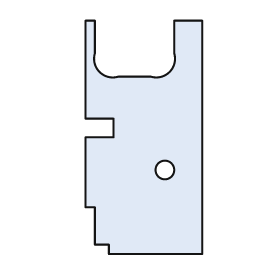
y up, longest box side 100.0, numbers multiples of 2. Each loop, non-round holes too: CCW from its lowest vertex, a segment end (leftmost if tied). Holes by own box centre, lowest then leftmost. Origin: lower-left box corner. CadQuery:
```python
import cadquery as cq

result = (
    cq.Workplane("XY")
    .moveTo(10.0, 0.0)
    .lineTo(50.0, 0.0)
    .lineTo(50.0, 100.0)
    .lineTo(38.0, 100.0)
    .lineTo(38.0, 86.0)
    .threePointArc((36.0, 78.0), (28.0, 76.0))
    .lineTo(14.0, 76.0)
    .threePointArc((6.0, 78.0), (4.0, 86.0))
    .lineTo(4.0, 100.0)
    .lineTo(0.0, 100.0)
    .lineTo(0.0, 58.0)
    .lineTo(12.0, 58.0)
    .lineTo(12.0, 50.0)
    .lineTo(0.0, 50.0)
    .lineTo(0.0, 20.0)
    .lineTo(4.0, 20.0)
    .lineTo(4.0, 4.0)
    .lineTo(10.0, 4.0)
    .close()
    .moveTo(34.0, 36.0)
    .circle(4.0)
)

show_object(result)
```